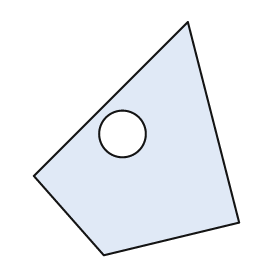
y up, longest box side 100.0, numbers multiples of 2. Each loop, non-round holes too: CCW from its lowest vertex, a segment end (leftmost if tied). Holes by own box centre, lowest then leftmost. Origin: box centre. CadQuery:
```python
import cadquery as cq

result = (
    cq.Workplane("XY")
    .moveTo(-14.0, -50.0)
    .lineTo(44.0, -36.0)
    .lineTo(22.0, 50.0)
    .lineTo(-44.0, -16.0)
    .close()
    .moveTo(-6.0, 2.0)
    .circle(10.0)
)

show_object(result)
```